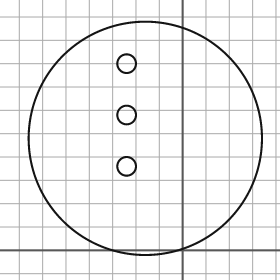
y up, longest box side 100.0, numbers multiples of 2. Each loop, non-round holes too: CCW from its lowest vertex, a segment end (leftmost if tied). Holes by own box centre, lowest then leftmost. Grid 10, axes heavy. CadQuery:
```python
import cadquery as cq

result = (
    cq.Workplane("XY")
    .moveTo(-16.0, 48.0)
    .circle(50.0)
    .moveTo(-24.0, 36.0)
    .circle(4.0)
    .moveTo(-24.0, 58.0)
    .circle(4.0)
    .moveTo(-24.0, 80.0)
    .circle(4.0)
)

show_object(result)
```